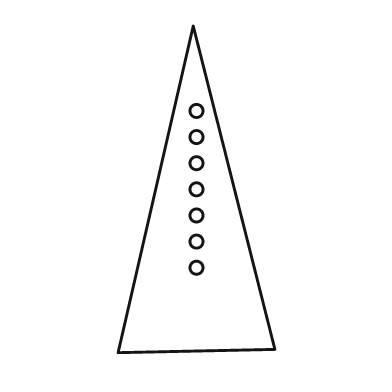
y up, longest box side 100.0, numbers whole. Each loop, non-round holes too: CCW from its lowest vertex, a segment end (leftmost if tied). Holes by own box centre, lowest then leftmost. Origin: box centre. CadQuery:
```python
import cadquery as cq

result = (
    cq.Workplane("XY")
    .moveTo(-24.0, -50.0)
    .lineTo(24.0, -49.0)
    .lineTo(-1.0, 50.0)
    .close()
    .moveTo(0.0, -24.0)
    .circle(2.0)
    .moveTo(0.0, -16.0)
    .circle(2.0)
    .moveTo(0.0, -8.0)
    .circle(2.0)
    .moveTo(0.0, 0.0)
    .circle(2.0)
    .moveTo(0.0, 8.0)
    .circle(2.0)
    .moveTo(0.0, 16.0)
    .circle(2.0)
    .moveTo(0.0, 24.0)
    .circle(2.0)
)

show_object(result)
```